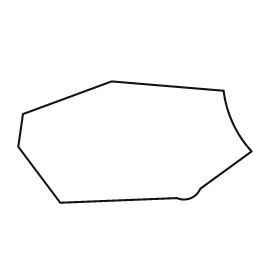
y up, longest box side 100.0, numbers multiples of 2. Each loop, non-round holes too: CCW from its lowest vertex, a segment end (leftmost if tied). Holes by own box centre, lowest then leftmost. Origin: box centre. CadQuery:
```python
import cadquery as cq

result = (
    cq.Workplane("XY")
    .moveTo(-32.0, -26.0)
    .lineTo(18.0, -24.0)
    .threePointArc((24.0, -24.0), (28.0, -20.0))
    .lineTo(50.0, -4.0)
    .threePointArc((42.0, 8.0), (38.0, 22.0))
    .lineTo(-10.0, 26.0)
    .lineTo(-48.0, 12.0)
    .lineTo(-50.0, -2.0)
    .close()
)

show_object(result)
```